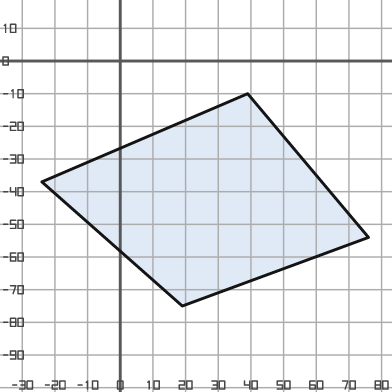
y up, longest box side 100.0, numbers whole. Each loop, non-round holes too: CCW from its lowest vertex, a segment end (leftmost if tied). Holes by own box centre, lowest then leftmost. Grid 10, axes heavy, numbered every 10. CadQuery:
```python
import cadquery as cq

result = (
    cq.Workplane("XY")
    .moveTo(19.0, -75.0)
    .lineTo(76.0, -54.0)
    .lineTo(39.0, -10.0)
    .lineTo(-24.0, -37.0)
    .close()
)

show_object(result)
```